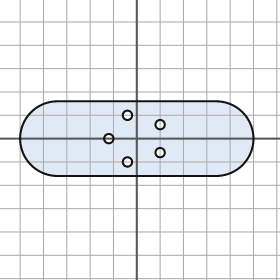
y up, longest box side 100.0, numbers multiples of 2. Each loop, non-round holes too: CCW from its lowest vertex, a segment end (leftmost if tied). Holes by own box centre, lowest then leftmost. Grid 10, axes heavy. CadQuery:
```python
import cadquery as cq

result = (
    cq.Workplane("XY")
    .moveTo(-34.0, -16.0)
    .lineTo(34.0, -16.0)
    .threePointArc((50.0, 0.0), (34.0, 16.0))
    .lineTo(-34.0, 16.0)
    .threePointArc((-50.0, 0.0), (-34.0, -16.0))
    .close()
    .moveTo(-4.0, -10.0)
    .circle(2.0)
    .moveTo(10.0, -6.0)
    .circle(2.0)
    .moveTo(-12.0, 0.0)
    .circle(2.0)
    .moveTo(10.0, 6.0)
    .circle(2.0)
    .moveTo(-4.0, 10.0)
    .circle(2.0)
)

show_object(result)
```